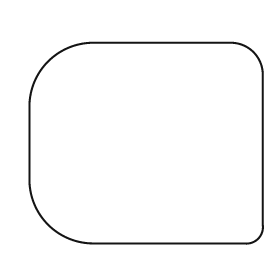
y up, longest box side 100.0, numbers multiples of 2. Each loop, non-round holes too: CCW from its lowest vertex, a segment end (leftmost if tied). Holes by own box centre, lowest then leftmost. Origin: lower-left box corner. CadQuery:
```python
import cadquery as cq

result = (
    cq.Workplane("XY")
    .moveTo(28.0, 0.0)
    .lineTo(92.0, 0.0)
    .threePointArc((98.0, 2.0), (100.0, 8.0))
    .lineTo(100.0, 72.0)
    .threePointArc((96.0, 82.0), (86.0, 86.0))
    .lineTo(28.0, 86.0)
    .threePointArc((8.0, 78.0), (0.0, 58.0))
    .lineTo(0.0, 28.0)
    .threePointArc((8.0, 8.0), (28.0, 0.0))
    .close()
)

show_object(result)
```